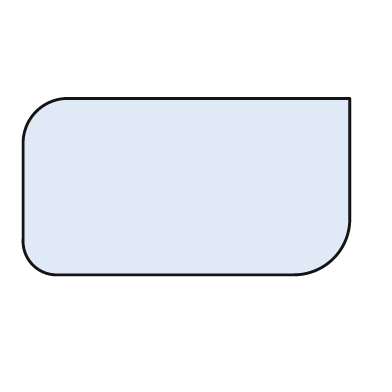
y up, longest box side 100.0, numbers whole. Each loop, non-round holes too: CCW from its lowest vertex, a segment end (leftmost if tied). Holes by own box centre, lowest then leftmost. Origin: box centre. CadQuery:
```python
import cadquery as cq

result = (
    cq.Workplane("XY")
    .moveTo(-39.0, -27.0)
    .lineTo(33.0, -27.0)
    .threePointArc((45.0, -22.0), (50.0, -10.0))
    .lineTo(50.0, 27.0)
    .lineTo(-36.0, 27.0)
    .threePointArc((-46.0, 23.0), (-50.0, 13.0))
    .lineTo(-50.0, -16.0)
    .threePointArc((-47.0, -24.0), (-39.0, -27.0))
    .close()
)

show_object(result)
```